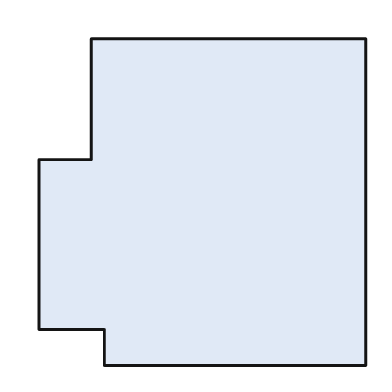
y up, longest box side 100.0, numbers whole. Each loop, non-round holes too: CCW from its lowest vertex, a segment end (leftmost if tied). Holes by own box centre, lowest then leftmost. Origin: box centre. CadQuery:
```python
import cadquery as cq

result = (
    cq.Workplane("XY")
    .moveTo(-30.0, -50.0)
    .lineTo(50.0, -50.0)
    .lineTo(50.0, 50.0)
    .lineTo(-34.0, 50.0)
    .lineTo(-34.0, 13.0)
    .lineTo(-50.0, 13.0)
    .lineTo(-50.0, -39.0)
    .lineTo(-30.0, -39.0)
    .close()
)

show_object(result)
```